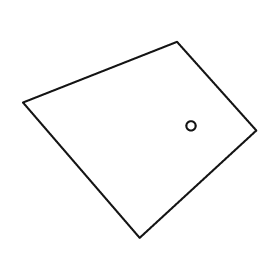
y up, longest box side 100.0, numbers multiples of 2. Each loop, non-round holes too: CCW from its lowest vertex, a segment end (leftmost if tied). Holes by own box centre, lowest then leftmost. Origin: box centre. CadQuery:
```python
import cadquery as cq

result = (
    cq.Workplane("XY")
    .moveTo(0.0, -42.0)
    .lineTo(50.0, 4.0)
    .lineTo(16.0, 42.0)
    .lineTo(-50.0, 16.0)
    .close()
    .moveTo(22.0, 6.0)
    .circle(2.0)
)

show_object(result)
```